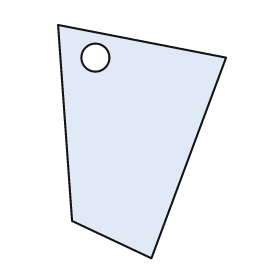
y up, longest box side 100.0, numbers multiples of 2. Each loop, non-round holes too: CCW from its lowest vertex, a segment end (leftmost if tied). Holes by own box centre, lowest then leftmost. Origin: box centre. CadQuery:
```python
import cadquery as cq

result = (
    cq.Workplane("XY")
    .moveTo(4.0, -50.0)
    .lineTo(36.0, 36.0)
    .lineTo(-36.0, 50.0)
    .lineTo(-30.0, -34.0)
    .close()
    .moveTo(-20.0, 36.0)
    .circle(6.0)
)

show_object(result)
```